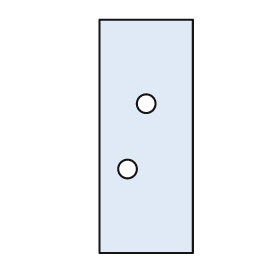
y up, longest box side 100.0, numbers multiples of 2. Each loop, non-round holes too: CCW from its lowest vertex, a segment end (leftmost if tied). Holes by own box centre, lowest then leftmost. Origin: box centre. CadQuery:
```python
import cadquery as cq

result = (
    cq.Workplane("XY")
    .moveTo(-20.0, -50.0)
    .lineTo(20.0, -50.0)
    .lineTo(20.0, 50.0)
    .lineTo(-20.0, 50.0)
    .close()
    .moveTo(-8.0, -14.0)
    .circle(4.0)
    .moveTo(0.0, 14.0)
    .circle(4.0)
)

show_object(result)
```